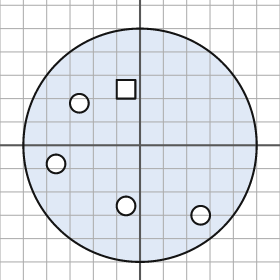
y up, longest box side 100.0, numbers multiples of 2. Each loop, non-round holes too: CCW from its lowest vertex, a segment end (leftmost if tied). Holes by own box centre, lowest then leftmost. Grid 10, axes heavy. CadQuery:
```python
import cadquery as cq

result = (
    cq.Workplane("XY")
    .moveTo(0.0, 0.0)
    .circle(50.0)
    .moveTo(26.0, -30.0)
    .circle(4.0)
    .moveTo(-6.0, -26.0)
    .circle(4.0)
    .moveTo(-36.0, -8.0)
    .circle(4.0)
    .moveTo(-26.0, 18.0)
    .circle(4.0)
    .moveTo(-10.0, 20.0)
    .lineTo(-2.0, 20.0)
    .lineTo(-2.0, 28.0)
    .lineTo(-10.0, 28.0)
    .close()
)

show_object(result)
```